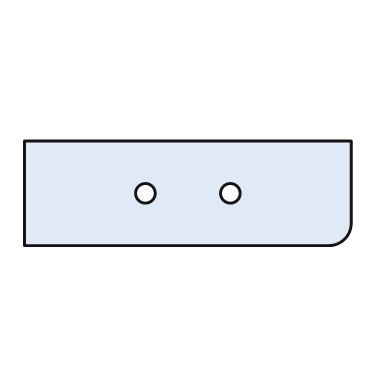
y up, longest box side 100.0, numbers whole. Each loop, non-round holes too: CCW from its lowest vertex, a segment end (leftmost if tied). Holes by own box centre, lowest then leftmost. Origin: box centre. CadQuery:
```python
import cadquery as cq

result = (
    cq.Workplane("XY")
    .moveTo(-50.0, -16.0)
    .lineTo(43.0, -16.0)
    .threePointArc((48.0, -14.0), (50.0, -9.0))
    .lineTo(50.0, 16.0)
    .lineTo(-50.0, 16.0)
    .close()
    .moveTo(-13.0, 0.0)
    .circle(3.0)
    .moveTo(13.0, 0.0)
    .circle(3.0)
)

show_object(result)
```